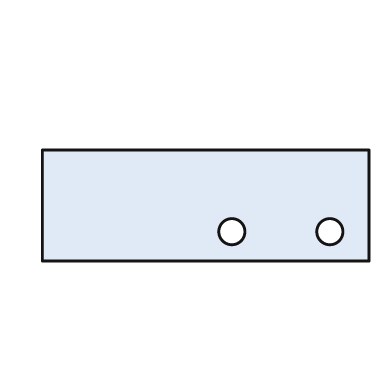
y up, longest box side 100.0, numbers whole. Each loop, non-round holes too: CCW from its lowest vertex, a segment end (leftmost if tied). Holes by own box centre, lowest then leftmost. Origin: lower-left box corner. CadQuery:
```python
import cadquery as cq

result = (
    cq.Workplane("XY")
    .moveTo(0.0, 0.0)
    .lineTo(100.0, 0.0)
    .lineTo(100.0, 34.0)
    .lineTo(0.0, 34.0)
    .close()
    .moveTo(58.0, 9.0)
    .circle(4.0)
    .moveTo(88.0, 9.0)
    .circle(4.0)
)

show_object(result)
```